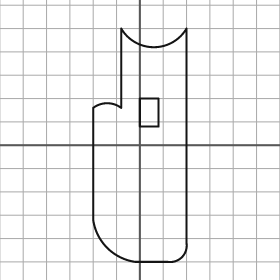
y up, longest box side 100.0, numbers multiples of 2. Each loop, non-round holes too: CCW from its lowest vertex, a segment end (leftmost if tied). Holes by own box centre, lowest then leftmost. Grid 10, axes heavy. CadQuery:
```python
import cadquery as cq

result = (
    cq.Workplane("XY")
    .moveTo(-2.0, -50.0)
    .lineTo(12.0, -50.0)
    .threePointArc((18.0, -48.0), (20.0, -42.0))
    .lineTo(20.0, 50.0)
    .threePointArc((6.0, 42.0), (-8.0, 50.0))
    .lineTo(-8.0, 16.0)
    .threePointArc((-14.0, 18.0), (-20.0, 16.0))
    .lineTo(-20.0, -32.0)
    .threePointArc((-14.0, -44.0), (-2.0, -50.0))
    .close()
    .moveTo(0.0, 8.0)
    .lineTo(8.0, 8.0)
    .lineTo(8.0, 20.0)
    .lineTo(0.0, 20.0)
    .close()
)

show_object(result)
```